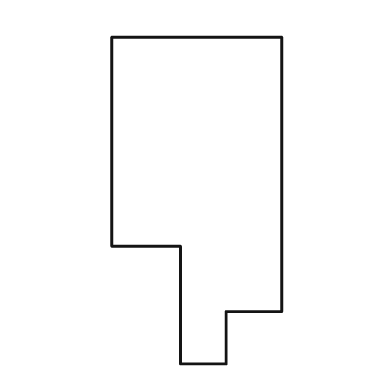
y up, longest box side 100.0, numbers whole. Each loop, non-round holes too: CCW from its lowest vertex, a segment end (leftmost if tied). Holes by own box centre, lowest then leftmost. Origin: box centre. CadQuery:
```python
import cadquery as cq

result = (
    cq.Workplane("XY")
    .moveTo(-5.0, -50.0)
    .lineTo(9.0, -50.0)
    .lineTo(9.0, -34.0)
    .lineTo(26.0, -34.0)
    .lineTo(26.0, 50.0)
    .lineTo(-26.0, 50.0)
    .lineTo(-26.0, -14.0)
    .lineTo(-5.0, -14.0)
    .close()
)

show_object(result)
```